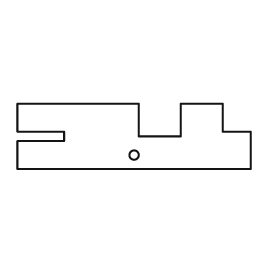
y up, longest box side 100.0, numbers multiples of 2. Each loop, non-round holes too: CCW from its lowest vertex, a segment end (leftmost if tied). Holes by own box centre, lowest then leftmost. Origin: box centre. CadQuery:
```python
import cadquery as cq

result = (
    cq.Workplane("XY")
    .moveTo(-50.0, -14.0)
    .lineTo(50.0, -14.0)
    .lineTo(50.0, 2.0)
    .lineTo(38.0, 2.0)
    .lineTo(38.0, 14.0)
    .lineTo(20.0, 14.0)
    .lineTo(20.0, 0.0)
    .lineTo(2.0, 0.0)
    .lineTo(2.0, 14.0)
    .lineTo(-50.0, 14.0)
    .lineTo(-50.0, 2.0)
    .lineTo(-30.0, 2.0)
    .lineTo(-30.0, -2.0)
    .lineTo(-50.0, -2.0)
    .close()
    .moveTo(0.0, -8.0)
    .circle(2.0)
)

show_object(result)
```